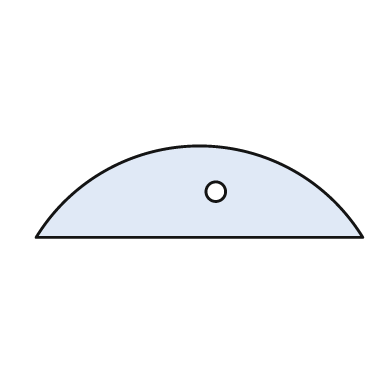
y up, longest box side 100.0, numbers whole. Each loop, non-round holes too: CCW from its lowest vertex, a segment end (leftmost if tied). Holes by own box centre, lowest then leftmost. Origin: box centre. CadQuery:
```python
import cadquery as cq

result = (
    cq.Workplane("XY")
    .moveTo(-50.0, -14.0)
    .lineTo(50.0, -14.0)
    .threePointArc((0.0, 14.0), (-50.0, -14.0))
    .close()
    .moveTo(5.0, 0.0)
    .circle(3.0)
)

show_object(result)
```